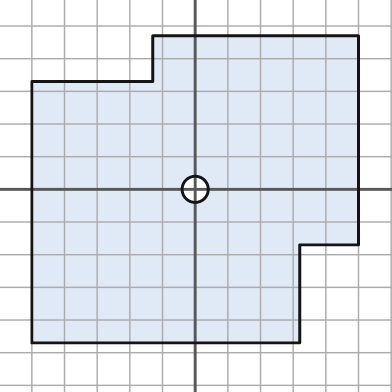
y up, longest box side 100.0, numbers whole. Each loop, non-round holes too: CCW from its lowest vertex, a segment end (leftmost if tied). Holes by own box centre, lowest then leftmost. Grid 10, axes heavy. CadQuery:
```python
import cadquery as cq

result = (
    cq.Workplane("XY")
    .moveTo(-50.0, -47.0)
    .lineTo(32.0, -47.0)
    .lineTo(32.0, -17.0)
    .lineTo(50.0, -17.0)
    .lineTo(50.0, 47.0)
    .lineTo(-13.0, 47.0)
    .lineTo(-13.0, 33.0)
    .lineTo(-50.0, 33.0)
    .close()
    .moveTo(0.0, 0.0)
    .circle(4.0)
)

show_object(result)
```